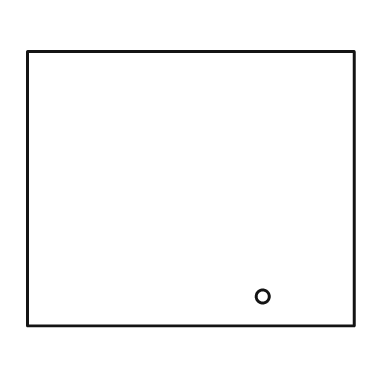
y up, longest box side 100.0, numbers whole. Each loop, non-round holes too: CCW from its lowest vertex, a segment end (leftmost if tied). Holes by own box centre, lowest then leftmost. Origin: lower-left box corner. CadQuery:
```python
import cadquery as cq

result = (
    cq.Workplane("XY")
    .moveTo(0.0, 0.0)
    .lineTo(100.0, 0.0)
    .lineTo(100.0, 84.0)
    .lineTo(0.0, 84.0)
    .close()
    .moveTo(72.0, 9.0)
    .circle(2.0)
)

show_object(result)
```